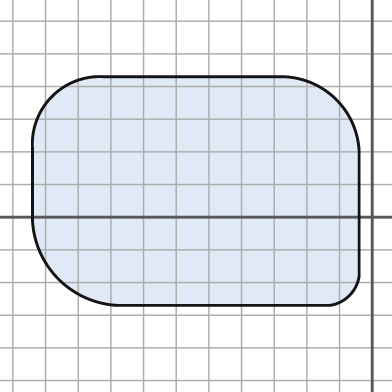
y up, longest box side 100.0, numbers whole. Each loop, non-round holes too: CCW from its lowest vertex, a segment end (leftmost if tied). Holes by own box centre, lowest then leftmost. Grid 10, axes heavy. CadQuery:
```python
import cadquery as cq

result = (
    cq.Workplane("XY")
    .moveTo(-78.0, -27.0)
    .lineTo(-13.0, -27.0)
    .threePointArc((-7.0, -24.0), (-4.0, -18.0))
    .lineTo(-4.0, 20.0)
    .threePointArc((-11.0, 36.0), (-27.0, 43.0))
    .lineTo(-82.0, 43.0)
    .threePointArc((-98.0, 37.0), (-104.0, 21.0))
    .lineTo(-104.0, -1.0)
    .threePointArc((-96.0, -19.0), (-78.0, -27.0))
    .close()
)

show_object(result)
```